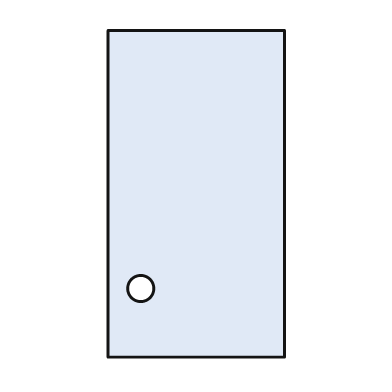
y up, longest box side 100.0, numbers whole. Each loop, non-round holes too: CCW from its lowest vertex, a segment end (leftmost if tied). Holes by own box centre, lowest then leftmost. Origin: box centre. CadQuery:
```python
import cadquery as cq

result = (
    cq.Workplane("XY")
    .moveTo(-27.0, -50.0)
    .lineTo(27.0, -50.0)
    .lineTo(27.0, 50.0)
    .lineTo(-27.0, 50.0)
    .close()
    .moveTo(-17.0, -29.0)
    .circle(4.0)
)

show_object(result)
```